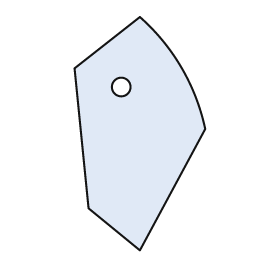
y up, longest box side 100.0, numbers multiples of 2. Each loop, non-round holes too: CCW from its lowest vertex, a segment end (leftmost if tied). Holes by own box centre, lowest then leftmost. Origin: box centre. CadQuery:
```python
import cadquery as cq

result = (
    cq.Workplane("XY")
    .moveTo(0.0, -50.0)
    .lineTo(28.0, 2.0)
    .threePointArc((18.0, 28.0), (0.0, 50.0))
    .lineTo(-28.0, 28.0)
    .lineTo(-22.0, -32.0)
    .close()
    .moveTo(-8.0, 20.0)
    .circle(4.0)
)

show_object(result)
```